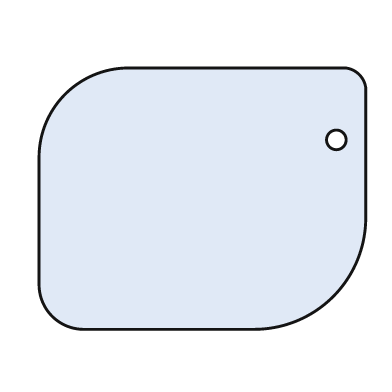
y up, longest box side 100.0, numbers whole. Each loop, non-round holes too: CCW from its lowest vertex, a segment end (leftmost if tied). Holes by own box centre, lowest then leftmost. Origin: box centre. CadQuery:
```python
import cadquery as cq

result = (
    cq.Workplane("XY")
    .moveTo(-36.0, -40.0)
    .lineTo(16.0, -40.0)
    .threePointArc((40.0, -30.0), (50.0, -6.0))
    .lineTo(50.0, 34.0)
    .threePointArc((48.0, 38.0), (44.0, 40.0))
    .lineTo(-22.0, 40.0)
    .threePointArc((-42.0, 32.0), (-50.0, 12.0))
    .lineTo(-50.0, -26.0)
    .threePointArc((-46.0, -36.0), (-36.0, -40.0))
    .close()
    .moveTo(41.0, 18.0)
    .circle(3.0)
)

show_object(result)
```